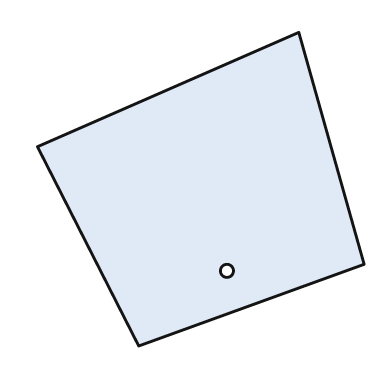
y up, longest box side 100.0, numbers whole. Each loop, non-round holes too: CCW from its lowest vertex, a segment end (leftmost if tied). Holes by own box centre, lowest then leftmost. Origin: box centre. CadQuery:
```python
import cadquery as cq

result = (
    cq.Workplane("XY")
    .moveTo(-19.0, -48.0)
    .lineTo(50.0, -23.0)
    .lineTo(30.0, 48.0)
    .lineTo(-50.0, 13.0)
    .close()
    .moveTo(8.0, -25.0)
    .circle(2.0)
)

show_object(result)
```